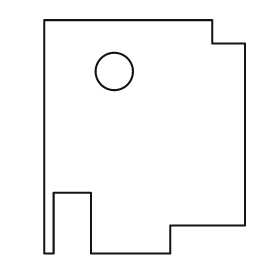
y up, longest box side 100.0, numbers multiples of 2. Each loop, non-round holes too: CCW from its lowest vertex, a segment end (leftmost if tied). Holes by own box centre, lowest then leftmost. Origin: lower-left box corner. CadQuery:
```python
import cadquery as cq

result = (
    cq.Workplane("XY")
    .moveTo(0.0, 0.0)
    .lineTo(4.0, 0.0)
    .lineTo(4.0, 26.0)
    .lineTo(20.0, 26.0)
    .lineTo(20.0, 0.0)
    .lineTo(54.0, 0.0)
    .lineTo(54.0, 12.0)
    .lineTo(86.0, 12.0)
    .lineTo(86.0, 90.0)
    .lineTo(72.0, 90.0)
    .lineTo(72.0, 100.0)
    .lineTo(0.0, 100.0)
    .close()
    .moveTo(30.0, 78.0)
    .circle(8.0)
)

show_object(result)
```